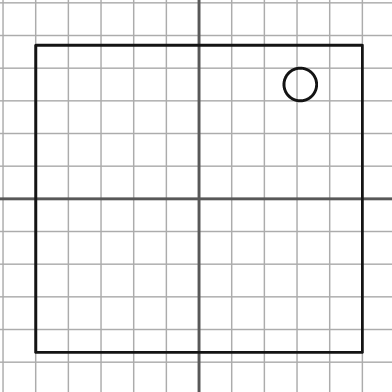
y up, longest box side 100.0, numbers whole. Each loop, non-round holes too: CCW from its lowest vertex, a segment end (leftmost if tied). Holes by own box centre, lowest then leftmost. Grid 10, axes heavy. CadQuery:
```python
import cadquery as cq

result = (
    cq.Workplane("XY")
    .moveTo(-50.0, -47.0)
    .lineTo(50.0, -47.0)
    .lineTo(50.0, 47.0)
    .lineTo(-50.0, 47.0)
    .close()
    .moveTo(31.0, 35.0)
    .circle(5.0)
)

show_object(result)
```